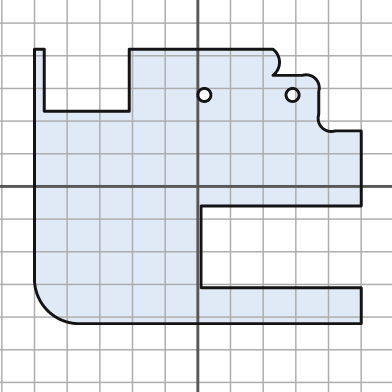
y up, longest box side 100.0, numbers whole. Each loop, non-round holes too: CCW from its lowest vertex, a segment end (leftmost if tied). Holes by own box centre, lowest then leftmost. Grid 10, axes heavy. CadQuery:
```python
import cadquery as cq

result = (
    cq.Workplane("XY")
    .moveTo(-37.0, -42.0)
    .lineTo(50.0, -42.0)
    .lineTo(50.0, -31.0)
    .lineTo(1.0, -31.0)
    .lineTo(1.0, -6.0)
    .lineTo(50.0, -6.0)
    .lineTo(50.0, 17.0)
    .lineTo(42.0, 17.0)
    .threePointArc((38.0, 18.0), (37.0, 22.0))
    .lineTo(37.0, 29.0)
    .threePointArc((36.0, 33.0), (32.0, 34.0))
    .lineTo(23.0, 34.0)
    .threePointArc((25.0, 38.0), (23.0, 42.0))
    .lineTo(-21.0, 42.0)
    .lineTo(-21.0, 23.0)
    .lineTo(-47.0, 23.0)
    .lineTo(-47.0, 42.0)
    .lineTo(-50.0, 42.0)
    .lineTo(-50.0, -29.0)
    .threePointArc((-46.0, -38.0), (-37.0, -42.0))
    .close()
    .moveTo(2.0, 28.0)
    .circle(2.0)
    .moveTo(29.0, 28.0)
    .circle(2.0)
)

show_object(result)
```